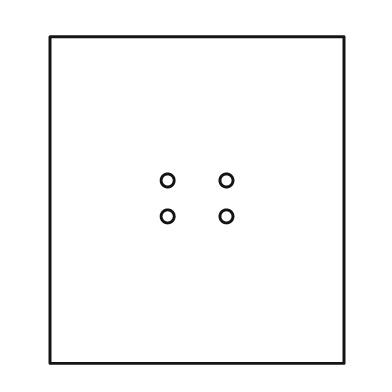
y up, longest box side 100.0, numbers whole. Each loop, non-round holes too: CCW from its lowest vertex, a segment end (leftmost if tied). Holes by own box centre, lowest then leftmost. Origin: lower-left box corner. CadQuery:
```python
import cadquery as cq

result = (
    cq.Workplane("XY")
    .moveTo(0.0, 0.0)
    .lineTo(90.0, 0.0)
    .lineTo(90.0, 100.0)
    .lineTo(0.0, 100.0)
    .close()
    .moveTo(36.0, 45.0)
    .circle(2.0)
    .moveTo(54.0, 45.0)
    .circle(2.0)
    .moveTo(36.0, 56.0)
    .circle(2.0)
    .moveTo(54.0, 56.0)
    .circle(2.0)
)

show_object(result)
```